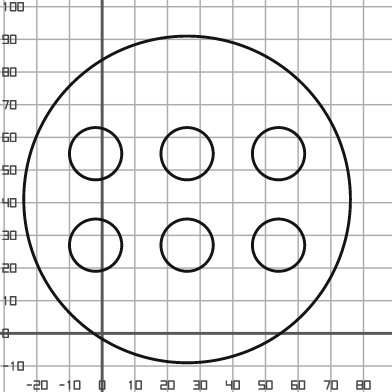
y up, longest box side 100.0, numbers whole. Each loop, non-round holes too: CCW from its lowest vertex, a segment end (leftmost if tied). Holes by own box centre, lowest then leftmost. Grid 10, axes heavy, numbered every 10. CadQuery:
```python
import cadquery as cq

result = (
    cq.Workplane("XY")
    .moveTo(26.0, 41.0)
    .circle(50.0)
    .moveTo(-2.0, 27.0)
    .circle(8.0)
    .moveTo(26.0, 27.0)
    .circle(8.0)
    .moveTo(54.0, 27.0)
    .circle(8.0)
    .moveTo(-2.0, 55.0)
    .circle(8.0)
    .moveTo(26.0, 55.0)
    .circle(8.0)
    .moveTo(54.0, 55.0)
    .circle(8.0)
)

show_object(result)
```